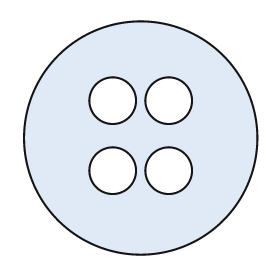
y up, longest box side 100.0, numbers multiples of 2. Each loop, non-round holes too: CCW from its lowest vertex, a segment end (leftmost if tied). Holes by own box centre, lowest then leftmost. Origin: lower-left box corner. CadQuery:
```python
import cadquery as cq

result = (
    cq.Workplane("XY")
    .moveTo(50.0, 50.0)
    .circle(50.0)
    .moveTo(38.0, 36.0)
    .circle(10.0)
    .moveTo(62.0, 36.0)
    .circle(10.0)
    .moveTo(38.0, 66.0)
    .circle(10.0)
    .moveTo(62.0, 66.0)
    .circle(10.0)
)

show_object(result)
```